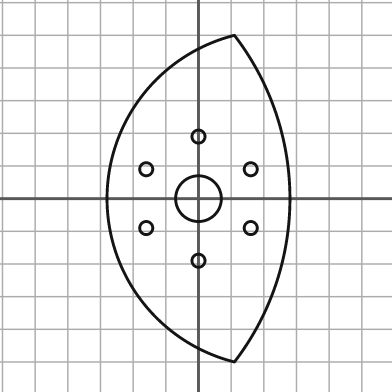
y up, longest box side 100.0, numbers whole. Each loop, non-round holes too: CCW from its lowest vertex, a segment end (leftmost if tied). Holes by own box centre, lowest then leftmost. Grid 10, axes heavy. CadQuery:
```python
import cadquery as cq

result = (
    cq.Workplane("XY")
    .moveTo(11.0, -50.0)
    .threePointArc((28.0, 0.0), (11.0, 50.0))
    .threePointArc((-28.0, 0.0), (11.0, -50.0))
    .close()
    .moveTo(0.0, -19.0)
    .circle(2.0)
    .moveTo(-16.0, -9.0)
    .circle(2.0)
    .moveTo(16.0, -9.0)
    .circle(2.0)
    .moveTo(0.0, 0.0)
    .circle(7.0)
    .moveTo(-16.0, 9.0)
    .circle(2.0)
    .moveTo(16.0, 9.0)
    .circle(2.0)
    .moveTo(0.0, 19.0)
    .circle(2.0)
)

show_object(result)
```